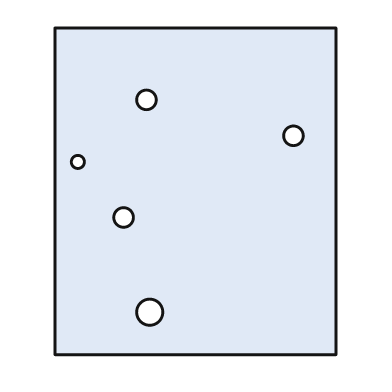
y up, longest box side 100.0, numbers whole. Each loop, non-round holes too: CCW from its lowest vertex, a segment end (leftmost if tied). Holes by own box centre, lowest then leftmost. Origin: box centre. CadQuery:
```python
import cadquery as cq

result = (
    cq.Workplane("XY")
    .moveTo(-43.0, -50.0)
    .lineTo(43.0, -50.0)
    .lineTo(43.0, 50.0)
    .lineTo(-43.0, 50.0)
    .close()
    .moveTo(-14.0, -37.0)
    .circle(4.0)
    .moveTo(-22.0, -8.0)
    .circle(3.0)
    .moveTo(-36.0, 9.0)
    .circle(2.0)
    .moveTo(30.0, 17.0)
    .circle(3.0)
    .moveTo(-15.0, 28.0)
    .circle(3.0)
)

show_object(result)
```